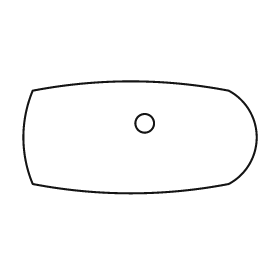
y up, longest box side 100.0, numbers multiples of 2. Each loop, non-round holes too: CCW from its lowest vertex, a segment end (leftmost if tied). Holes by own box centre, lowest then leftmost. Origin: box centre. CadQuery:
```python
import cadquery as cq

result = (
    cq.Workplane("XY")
    .moveTo(-46.0, -20.0)
    .threePointArc((-4.0, -24.0), (38.0, -20.0))
    .threePointArc((50.0, 0.0), (38.0, 20.0))
    .threePointArc((-4.0, 24.0), (-46.0, 20.0))
    .threePointArc((-50.0, 0.0), (-46.0, -20.0))
    .close()
    .moveTo(2.0, 6.0)
    .circle(4.0)
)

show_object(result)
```